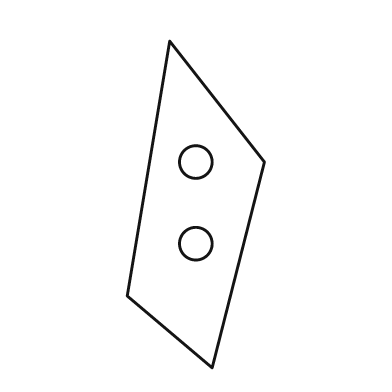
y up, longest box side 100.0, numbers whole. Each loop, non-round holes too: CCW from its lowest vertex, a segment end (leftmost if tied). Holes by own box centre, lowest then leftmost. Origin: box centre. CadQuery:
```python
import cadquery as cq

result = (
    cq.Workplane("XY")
    .moveTo(5.0, -50.0)
    .lineTo(21.0, 13.0)
    .lineTo(-8.0, 50.0)
    .lineTo(-21.0, -28.0)
    .close()
    .moveTo(0.0, -12.0)
    .circle(5.0)
    .moveTo(0.0, 13.0)
    .circle(5.0)
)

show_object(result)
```